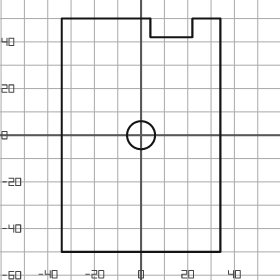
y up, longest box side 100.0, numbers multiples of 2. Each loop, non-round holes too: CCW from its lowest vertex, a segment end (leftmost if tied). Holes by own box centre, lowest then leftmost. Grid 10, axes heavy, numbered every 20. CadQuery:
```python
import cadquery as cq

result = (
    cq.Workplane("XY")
    .moveTo(-34.0, -50.0)
    .lineTo(34.0, -50.0)
    .lineTo(34.0, 50.0)
    .lineTo(22.0, 50.0)
    .lineTo(22.0, 42.0)
    .lineTo(4.0, 42.0)
    .lineTo(4.0, 50.0)
    .lineTo(-34.0, 50.0)
    .close()
    .moveTo(0.0, 0.0)
    .circle(6.0)
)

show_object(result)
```